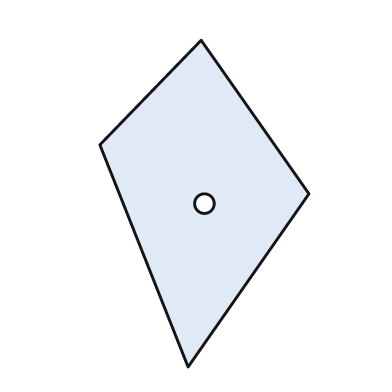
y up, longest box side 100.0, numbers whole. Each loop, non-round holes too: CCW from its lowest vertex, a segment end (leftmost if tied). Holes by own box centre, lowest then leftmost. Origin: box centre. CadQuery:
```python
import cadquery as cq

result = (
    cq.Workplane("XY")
    .moveTo(-5.0, -50.0)
    .lineTo(32.0, 3.0)
    .lineTo(-1.0, 50.0)
    .lineTo(-32.0, 18.0)
    .close()
    .moveTo(0.0, 0.0)
    .circle(3.0)
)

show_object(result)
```